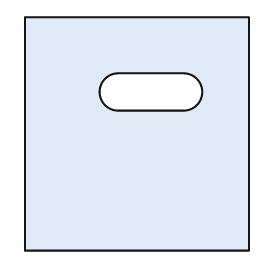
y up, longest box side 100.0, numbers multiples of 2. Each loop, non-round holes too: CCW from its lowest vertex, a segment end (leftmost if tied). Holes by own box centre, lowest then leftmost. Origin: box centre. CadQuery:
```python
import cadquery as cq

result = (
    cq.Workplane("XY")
    .moveTo(-48.0, -50.0)
    .lineTo(48.0, -50.0)
    .lineTo(48.0, 50.0)
    .lineTo(-48.0, 50.0)
    .close()
    .moveTo(-8.0, 10.0)
    .lineTo(20.0, 10.0)
    .threePointArc((28.0, 18.0), (20.0, 26.0))
    .lineTo(-8.0, 26.0)
    .threePointArc((-16.0, 18.0), (-8.0, 10.0))
    .close()
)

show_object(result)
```